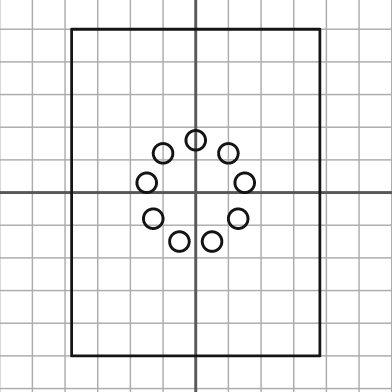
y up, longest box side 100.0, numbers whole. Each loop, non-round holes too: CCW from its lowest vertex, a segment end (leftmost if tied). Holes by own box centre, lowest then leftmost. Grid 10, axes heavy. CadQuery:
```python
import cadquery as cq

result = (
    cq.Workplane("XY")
    .moveTo(-38.0, -50.0)
    .lineTo(38.0, -50.0)
    .lineTo(38.0, 50.0)
    .lineTo(-38.0, 50.0)
    .close()
    .moveTo(-5.0, -15.0)
    .circle(3.0)
    .moveTo(5.0, -15.0)
    .circle(3.0)
    .moveTo(-13.0, -8.0)
    .circle(3.0)
    .moveTo(13.0, -8.0)
    .circle(3.0)
    .moveTo(-15.0, 3.0)
    .circle(3.0)
    .moveTo(15.0, 3.0)
    .circle(3.0)
    .moveTo(-10.0, 12.0)
    .circle(3.0)
    .moveTo(10.0, 12.0)
    .circle(3.0)
    .moveTo(0.0, 16.0)
    .circle(3.0)
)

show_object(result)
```